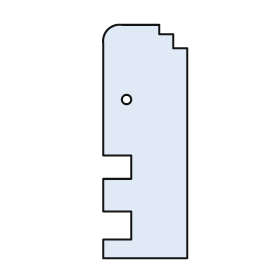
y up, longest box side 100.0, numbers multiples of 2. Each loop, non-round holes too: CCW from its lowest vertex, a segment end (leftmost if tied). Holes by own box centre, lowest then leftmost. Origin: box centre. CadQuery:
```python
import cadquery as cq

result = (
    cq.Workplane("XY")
    .moveTo(-18.0, -50.0)
    .lineTo(18.0, -50.0)
    .lineTo(18.0, 40.0)
    .lineTo(12.0, 40.0)
    .lineTo(12.0, 46.0)
    .lineTo(6.0, 46.0)
    .lineTo(6.0, 50.0)
    .lineTo(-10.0, 50.0)
    .threePointArc((-16.0, 48.0), (-18.0, 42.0))
    .lineTo(-18.0, -6.0)
    .lineTo(-6.0, -6.0)
    .lineTo(-6.0, -16.0)
    .lineTo(-18.0, -16.0)
    .lineTo(-18.0, -30.0)
    .lineTo(-6.0, -30.0)
    .lineTo(-6.0, -42.0)
    .lineTo(-18.0, -42.0)
    .close()
    .moveTo(-8.0, 18.0)
    .circle(2.0)
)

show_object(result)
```